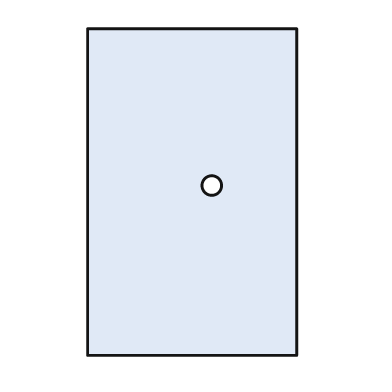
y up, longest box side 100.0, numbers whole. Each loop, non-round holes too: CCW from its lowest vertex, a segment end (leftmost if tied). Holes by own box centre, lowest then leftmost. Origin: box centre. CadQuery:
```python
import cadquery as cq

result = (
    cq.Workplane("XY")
    .moveTo(-32.0, -50.0)
    .lineTo(32.0, -50.0)
    .lineTo(32.0, 50.0)
    .lineTo(-32.0, 50.0)
    .close()
    .moveTo(6.0, 2.0)
    .circle(3.0)
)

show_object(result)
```